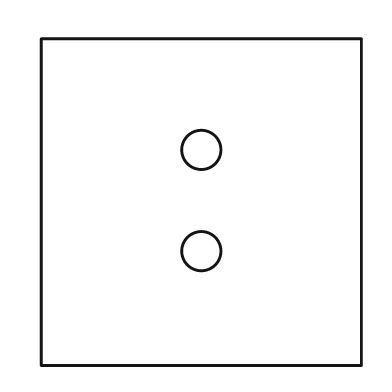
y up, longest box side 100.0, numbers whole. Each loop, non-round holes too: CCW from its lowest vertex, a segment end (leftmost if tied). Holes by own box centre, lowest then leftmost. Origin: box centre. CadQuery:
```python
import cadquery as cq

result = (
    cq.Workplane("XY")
    .moveTo(-49.0, -50.0)
    .lineTo(49.0, -50.0)
    .lineTo(49.0, 50.0)
    .lineTo(-49.0, 50.0)
    .close()
    .moveTo(0.0, -15.0)
    .circle(6.0)
    .moveTo(0.0, 16.0)
    .circle(6.0)
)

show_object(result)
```